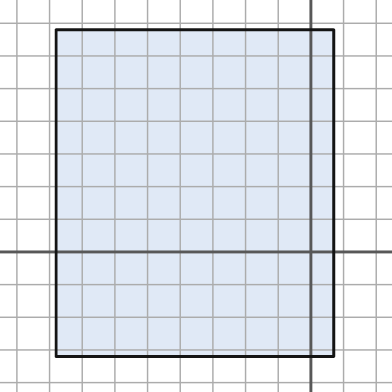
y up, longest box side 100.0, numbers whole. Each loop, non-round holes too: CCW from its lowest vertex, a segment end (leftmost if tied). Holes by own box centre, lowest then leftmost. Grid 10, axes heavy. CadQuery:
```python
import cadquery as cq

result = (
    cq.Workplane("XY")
    .moveTo(-78.0, -32.0)
    .lineTo(7.0, -32.0)
    .lineTo(7.0, 68.0)
    .lineTo(-78.0, 68.0)
    .close()
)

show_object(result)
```